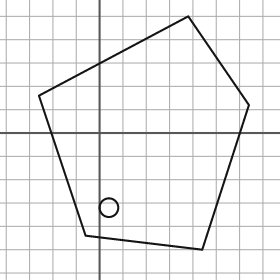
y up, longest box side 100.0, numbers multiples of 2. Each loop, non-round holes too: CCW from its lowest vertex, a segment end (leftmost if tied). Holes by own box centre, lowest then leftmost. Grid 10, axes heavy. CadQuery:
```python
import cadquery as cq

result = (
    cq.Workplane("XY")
    .moveTo(44.0, -50.0)
    .lineTo(64.0, 12.0)
    .lineTo(38.0, 50.0)
    .lineTo(-26.0, 16.0)
    .lineTo(-6.0, -44.0)
    .close()
    .moveTo(4.0, -32.0)
    .circle(4.0)
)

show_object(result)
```